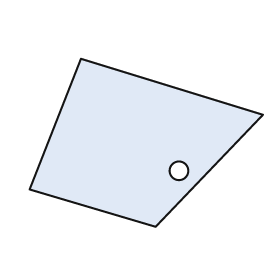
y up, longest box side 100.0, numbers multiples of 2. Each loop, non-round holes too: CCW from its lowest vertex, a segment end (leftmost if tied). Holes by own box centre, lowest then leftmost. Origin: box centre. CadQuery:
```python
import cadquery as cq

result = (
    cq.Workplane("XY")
    .moveTo(4.0, -36.0)
    .lineTo(50.0, 12.0)
    .lineTo(-28.0, 36.0)
    .lineTo(-50.0, -20.0)
    .close()
    .moveTo(14.0, -12.0)
    .circle(4.0)
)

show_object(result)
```